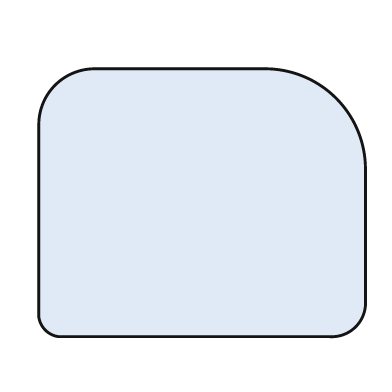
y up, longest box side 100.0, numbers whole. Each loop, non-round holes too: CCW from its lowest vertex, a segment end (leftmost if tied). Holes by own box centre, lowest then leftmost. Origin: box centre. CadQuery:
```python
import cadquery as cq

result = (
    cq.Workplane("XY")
    .moveTo(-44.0, -41.0)
    .lineTo(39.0, -41.0)
    .threePointArc((47.0, -38.0), (50.0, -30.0))
    .lineTo(50.0, 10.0)
    .threePointArc((41.0, 32.0), (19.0, 41.0))
    .lineTo(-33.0, 41.0)
    .threePointArc((-45.0, 36.0), (-50.0, 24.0))
    .lineTo(-50.0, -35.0)
    .threePointArc((-48.0, -39.0), (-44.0, -41.0))
    .close()
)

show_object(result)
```